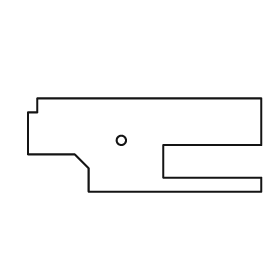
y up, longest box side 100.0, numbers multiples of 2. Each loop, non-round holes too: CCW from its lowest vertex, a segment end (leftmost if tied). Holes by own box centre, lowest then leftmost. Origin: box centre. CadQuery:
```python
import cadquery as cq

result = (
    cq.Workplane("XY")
    .moveTo(-24.0, -20.0)
    .lineTo(50.0, -20.0)
    .lineTo(50.0, -14.0)
    .lineTo(8.0, -14.0)
    .lineTo(8.0, 0.0)
    .lineTo(50.0, 0.0)
    .lineTo(50.0, 20.0)
    .lineTo(-46.0, 20.0)
    .lineTo(-46.0, 14.0)
    .lineTo(-50.0, 14.0)
    .lineTo(-50.0, -4.0)
    .lineTo(-30.0, -4.0)
    .lineTo(-24.0, -10.0)
    .close()
    .moveTo(-10.0, 2.0)
    .circle(2.0)
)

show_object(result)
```